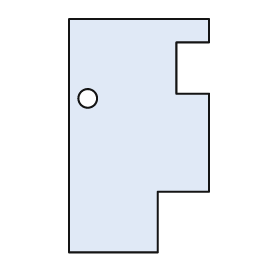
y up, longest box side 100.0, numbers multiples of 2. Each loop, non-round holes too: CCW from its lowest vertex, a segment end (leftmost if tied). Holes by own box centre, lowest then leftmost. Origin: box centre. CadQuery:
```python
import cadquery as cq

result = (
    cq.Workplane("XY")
    .moveTo(-30.0, -50.0)
    .lineTo(8.0, -50.0)
    .lineTo(8.0, -24.0)
    .lineTo(30.0, -24.0)
    .lineTo(30.0, 18.0)
    .lineTo(16.0, 18.0)
    .lineTo(16.0, 40.0)
    .lineTo(30.0, 40.0)
    .lineTo(30.0, 50.0)
    .lineTo(-30.0, 50.0)
    .close()
    .moveTo(-22.0, 16.0)
    .circle(4.0)
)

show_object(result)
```